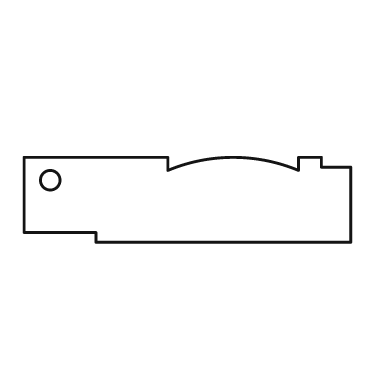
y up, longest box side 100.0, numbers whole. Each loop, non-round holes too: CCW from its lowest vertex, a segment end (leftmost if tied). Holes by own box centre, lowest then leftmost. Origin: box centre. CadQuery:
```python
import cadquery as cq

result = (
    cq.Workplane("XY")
    .moveTo(-28.0, -13.0)
    .lineTo(50.0, -13.0)
    .lineTo(50.0, 10.0)
    .lineTo(41.0, 10.0)
    .lineTo(41.0, 13.0)
    .lineTo(34.0, 13.0)
    .lineTo(34.0, 9.0)
    .threePointArc((14.0, 13.0), (-6.0, 9.0))
    .lineTo(-6.0, 13.0)
    .lineTo(-50.0, 13.0)
    .lineTo(-50.0, -10.0)
    .lineTo(-28.0, -10.0)
    .close()
    .moveTo(-42.0, 6.0)
    .circle(3.0)
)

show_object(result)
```